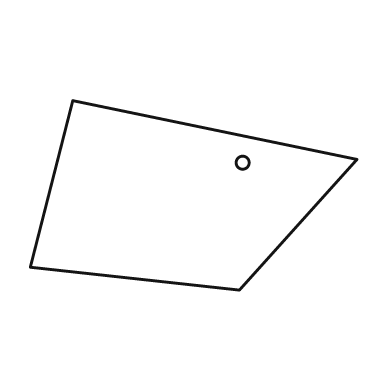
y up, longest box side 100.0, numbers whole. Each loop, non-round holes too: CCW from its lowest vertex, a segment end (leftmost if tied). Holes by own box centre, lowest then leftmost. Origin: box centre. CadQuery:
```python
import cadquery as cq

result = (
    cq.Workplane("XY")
    .moveTo(14.0, -29.0)
    .lineTo(50.0, 11.0)
    .lineTo(-37.0, 29.0)
    .lineTo(-50.0, -22.0)
    .close()
    .moveTo(15.0, 10.0)
    .circle(2.0)
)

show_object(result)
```